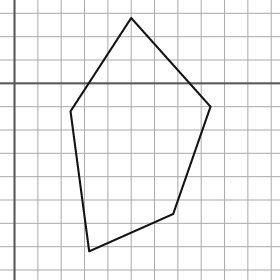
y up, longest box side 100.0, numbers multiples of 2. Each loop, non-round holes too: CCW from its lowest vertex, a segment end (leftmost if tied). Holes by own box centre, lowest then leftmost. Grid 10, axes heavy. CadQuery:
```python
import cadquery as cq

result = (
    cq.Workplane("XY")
    .moveTo(32.0, -72.0)
    .lineTo(68.0, -56.0)
    .lineTo(84.0, -10.0)
    .lineTo(50.0, 28.0)
    .lineTo(24.0, -12.0)
    .close()
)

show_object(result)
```